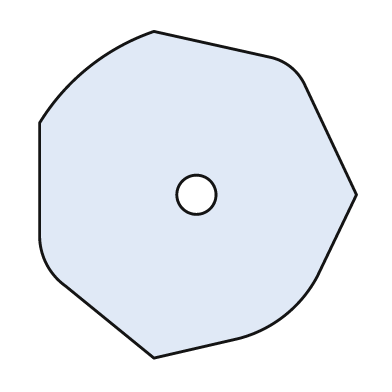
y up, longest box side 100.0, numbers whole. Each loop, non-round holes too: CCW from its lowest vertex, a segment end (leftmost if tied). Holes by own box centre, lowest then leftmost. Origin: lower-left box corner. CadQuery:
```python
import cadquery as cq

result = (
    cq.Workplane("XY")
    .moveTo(35.0, 0.0)
    .lineTo(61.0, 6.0)
    .threePointArc((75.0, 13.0), (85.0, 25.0))
    .lineTo(97.0, 50.0)
    .lineTo(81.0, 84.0)
    .threePointArc((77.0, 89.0), (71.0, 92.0))
    .lineTo(35.0, 100.0)
    .threePointArc((15.0, 89.0), (0.0, 72.0))
    .lineTo(0.0, 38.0)
    .threePointArc((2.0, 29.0), (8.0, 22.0))
    .close()
    .moveTo(48.0, 50.0)
    .circle(6.0)
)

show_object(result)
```